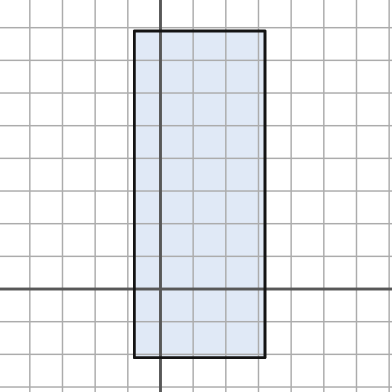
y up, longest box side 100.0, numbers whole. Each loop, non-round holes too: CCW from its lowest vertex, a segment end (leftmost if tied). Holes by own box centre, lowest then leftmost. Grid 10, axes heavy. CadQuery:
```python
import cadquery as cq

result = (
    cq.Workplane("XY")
    .moveTo(-8.0, -21.0)
    .lineTo(32.0, -21.0)
    .lineTo(32.0, 79.0)
    .lineTo(-8.0, 79.0)
    .close()
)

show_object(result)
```